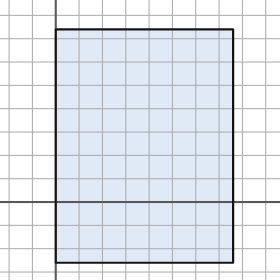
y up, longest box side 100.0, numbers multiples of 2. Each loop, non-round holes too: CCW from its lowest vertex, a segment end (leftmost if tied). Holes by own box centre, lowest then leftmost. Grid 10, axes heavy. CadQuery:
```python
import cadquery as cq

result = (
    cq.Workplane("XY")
    .moveTo(0.0, -26.0)
    .lineTo(76.0, -26.0)
    .lineTo(76.0, 74.0)
    .lineTo(0.0, 74.0)
    .close()
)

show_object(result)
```